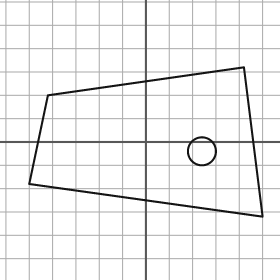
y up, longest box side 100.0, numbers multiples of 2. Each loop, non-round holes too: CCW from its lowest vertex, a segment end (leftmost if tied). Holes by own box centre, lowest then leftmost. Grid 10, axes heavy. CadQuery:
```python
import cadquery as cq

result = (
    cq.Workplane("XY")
    .moveTo(50.0, -32.0)
    .lineTo(42.0, 32.0)
    .lineTo(-42.0, 20.0)
    .lineTo(-50.0, -18.0)
    .close()
    .moveTo(24.0, -4.0)
    .circle(6.0)
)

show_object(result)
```